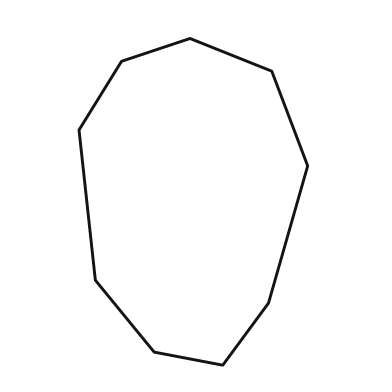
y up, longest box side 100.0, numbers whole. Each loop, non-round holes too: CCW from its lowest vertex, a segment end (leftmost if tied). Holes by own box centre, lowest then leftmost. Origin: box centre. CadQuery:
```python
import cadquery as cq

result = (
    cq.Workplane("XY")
    .moveTo(9.0, -50.0)
    .lineTo(23.0, -31.0)
    .lineTo(35.0, 11.0)
    .lineTo(24.0, 40.0)
    .lineTo(-1.0, 50.0)
    .lineTo(-22.0, 43.0)
    .lineTo(-35.0, 22.0)
    .lineTo(-30.0, -24.0)
    .lineTo(-12.0, -46.0)
    .close()
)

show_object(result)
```